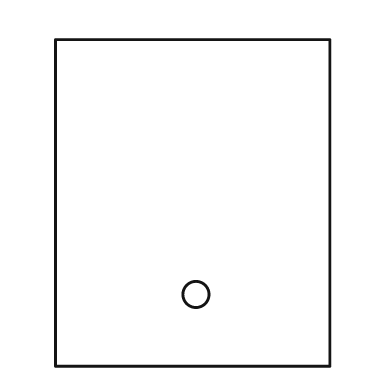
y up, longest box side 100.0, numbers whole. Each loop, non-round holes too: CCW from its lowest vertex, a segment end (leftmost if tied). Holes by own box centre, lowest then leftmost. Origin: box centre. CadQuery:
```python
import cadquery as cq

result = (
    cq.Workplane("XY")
    .moveTo(-42.0, -50.0)
    .lineTo(42.0, -50.0)
    .lineTo(42.0, 50.0)
    .lineTo(-42.0, 50.0)
    .close()
    .moveTo(1.0, -28.0)
    .circle(4.0)
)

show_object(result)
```